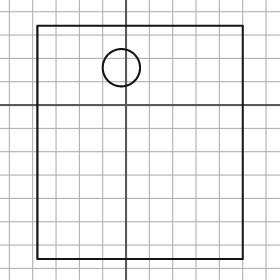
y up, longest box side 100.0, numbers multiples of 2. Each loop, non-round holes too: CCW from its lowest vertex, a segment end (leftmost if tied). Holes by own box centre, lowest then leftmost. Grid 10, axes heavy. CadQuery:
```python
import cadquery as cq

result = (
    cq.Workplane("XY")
    .moveTo(-38.0, -66.0)
    .lineTo(50.0, -66.0)
    .lineTo(50.0, 34.0)
    .lineTo(-38.0, 34.0)
    .close()
    .moveTo(-2.0, 16.0)
    .circle(8.0)
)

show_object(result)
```